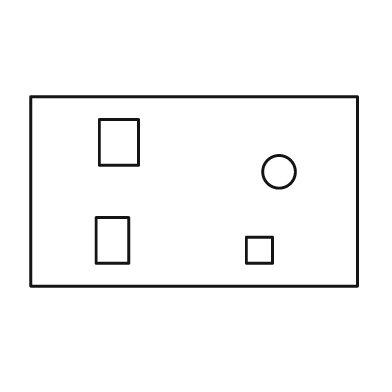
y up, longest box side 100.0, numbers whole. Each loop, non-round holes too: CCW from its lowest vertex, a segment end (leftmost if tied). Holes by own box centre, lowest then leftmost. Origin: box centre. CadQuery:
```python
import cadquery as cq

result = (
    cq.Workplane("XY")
    .moveTo(-50.0, -29.0)
    .lineTo(50.0, -29.0)
    .lineTo(50.0, 29.0)
    .lineTo(-50.0, 29.0)
    .close()
    .moveTo(16.0, -22.0)
    .lineTo(24.0, -22.0)
    .lineTo(24.0, -14.0)
    .lineTo(16.0, -14.0)
    .close()
    .moveTo(-30.0, -22.0)
    .lineTo(-20.0, -22.0)
    .lineTo(-20.0, -8.0)
    .lineTo(-30.0, -8.0)
    .close()
    .moveTo(26.0, 6.0)
    .circle(5.0)
    .moveTo(-29.0, 8.0)
    .lineTo(-17.0, 8.0)
    .lineTo(-17.0, 22.0)
    .lineTo(-29.0, 22.0)
    .close()
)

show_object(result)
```